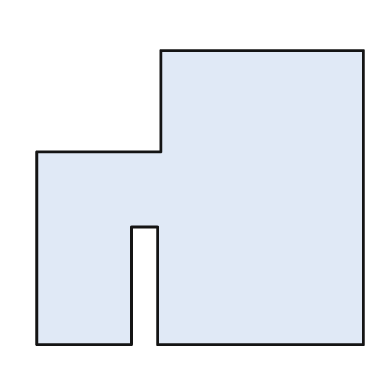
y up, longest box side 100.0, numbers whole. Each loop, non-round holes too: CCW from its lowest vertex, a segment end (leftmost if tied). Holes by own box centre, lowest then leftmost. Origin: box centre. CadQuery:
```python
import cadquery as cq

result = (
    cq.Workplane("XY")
    .moveTo(-50.0, -45.0)
    .lineTo(-21.0, -45.0)
    .lineTo(-21.0, -9.0)
    .lineTo(-13.0, -9.0)
    .lineTo(-13.0, -45.0)
    .lineTo(50.0, -45.0)
    .lineTo(50.0, 45.0)
    .lineTo(-12.0, 45.0)
    .lineTo(-12.0, 14.0)
    .lineTo(-50.0, 14.0)
    .close()
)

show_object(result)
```